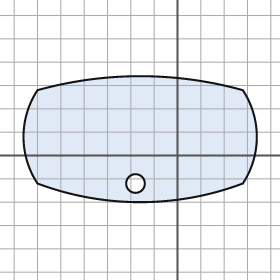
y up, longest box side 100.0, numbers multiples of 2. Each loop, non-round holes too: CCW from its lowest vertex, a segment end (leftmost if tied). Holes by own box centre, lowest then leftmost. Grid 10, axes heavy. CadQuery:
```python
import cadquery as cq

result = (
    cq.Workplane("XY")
    .moveTo(-60.0, -12.0)
    .threePointArc((-16.0, -20.0), (28.0, -12.0))
    .threePointArc((34.0, 8.0), (28.0, 28.0))
    .threePointArc((-16.0, 34.0), (-60.0, 28.0))
    .threePointArc((-66.0, 8.0), (-60.0, -12.0))
    .close()
    .moveTo(-18.0, -12.0)
    .circle(4.0)
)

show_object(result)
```